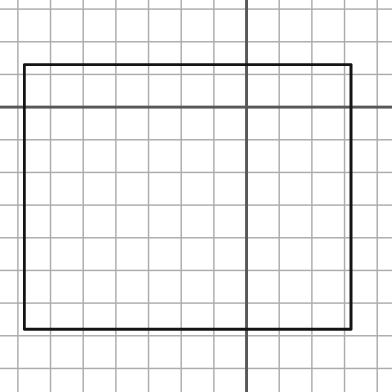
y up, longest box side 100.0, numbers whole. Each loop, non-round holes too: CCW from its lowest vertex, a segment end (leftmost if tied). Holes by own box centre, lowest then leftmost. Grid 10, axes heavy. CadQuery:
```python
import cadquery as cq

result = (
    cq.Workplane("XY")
    .moveTo(-68.0, -68.0)
    .lineTo(32.0, -68.0)
    .lineTo(32.0, 13.0)
    .lineTo(-68.0, 13.0)
    .close()
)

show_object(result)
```